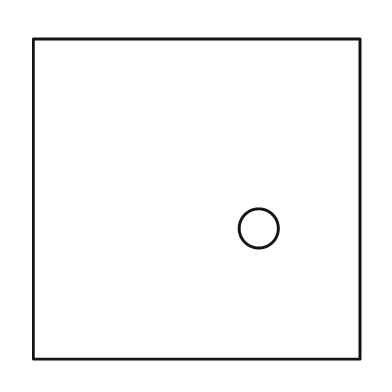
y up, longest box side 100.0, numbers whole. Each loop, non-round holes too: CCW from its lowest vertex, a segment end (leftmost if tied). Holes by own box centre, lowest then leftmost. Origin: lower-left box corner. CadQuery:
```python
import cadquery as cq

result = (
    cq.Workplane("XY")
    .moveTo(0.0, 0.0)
    .lineTo(100.0, 0.0)
    .lineTo(100.0, 98.0)
    .lineTo(0.0, 98.0)
    .close()
    .moveTo(69.0, 40.0)
    .circle(6.0)
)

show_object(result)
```